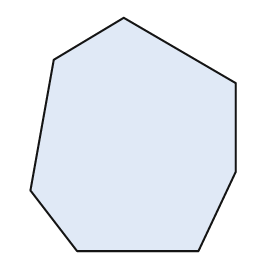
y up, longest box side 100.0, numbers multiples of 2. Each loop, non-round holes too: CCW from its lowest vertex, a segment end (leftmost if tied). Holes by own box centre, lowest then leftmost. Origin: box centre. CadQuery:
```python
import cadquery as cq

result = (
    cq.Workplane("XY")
    .moveTo(-24.0, -50.0)
    .lineTo(28.0, -50.0)
    .lineTo(44.0, -16.0)
    .lineTo(44.0, 22.0)
    .lineTo(-4.0, 50.0)
    .lineTo(-34.0, 32.0)
    .lineTo(-44.0, -24.0)
    .close()
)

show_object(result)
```